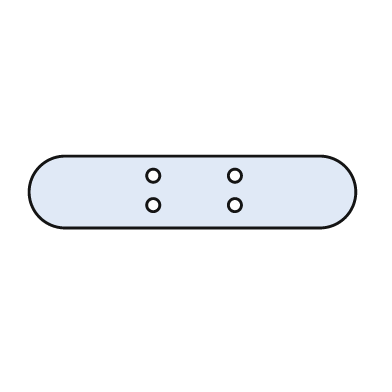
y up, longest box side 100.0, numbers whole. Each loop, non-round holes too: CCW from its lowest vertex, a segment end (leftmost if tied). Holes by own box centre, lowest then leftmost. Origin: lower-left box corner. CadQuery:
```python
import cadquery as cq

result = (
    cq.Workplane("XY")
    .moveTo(11.0, 0.0)
    .lineTo(89.0, 0.0)
    .threePointArc((100.0, 11.0), (89.0, 22.0))
    .lineTo(11.0, 22.0)
    .threePointArc((0.0, 11.0), (11.0, 0.0))
    .close()
    .moveTo(38.0, 7.0)
    .circle(2.0)
    .moveTo(63.0, 7.0)
    .circle(2.0)
    .moveTo(38.0, 16.0)
    .circle(2.0)
    .moveTo(63.0, 16.0)
    .circle(2.0)
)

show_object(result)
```